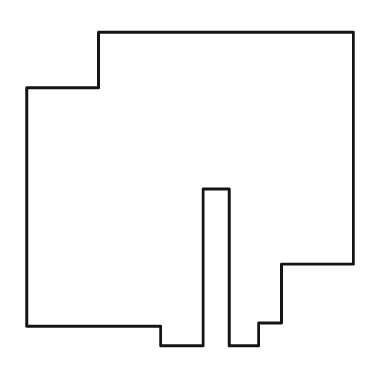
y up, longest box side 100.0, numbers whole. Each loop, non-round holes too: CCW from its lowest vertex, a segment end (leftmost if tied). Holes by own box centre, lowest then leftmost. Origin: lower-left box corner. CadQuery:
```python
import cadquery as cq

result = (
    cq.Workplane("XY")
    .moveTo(41.0, 0.0)
    .lineTo(54.0, 0.0)
    .lineTo(54.0, 48.0)
    .lineTo(62.0, 48.0)
    .lineTo(62.0, 0.0)
    .lineTo(71.0, 0.0)
    .lineTo(71.0, 7.0)
    .lineTo(78.0, 7.0)
    .lineTo(78.0, 25.0)
    .lineTo(100.0, 25.0)
    .lineTo(100.0, 96.0)
    .lineTo(22.0, 96.0)
    .lineTo(22.0, 79.0)
    .lineTo(0.0, 79.0)
    .lineTo(0.0, 6.0)
    .lineTo(41.0, 6.0)
    .close()
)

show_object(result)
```